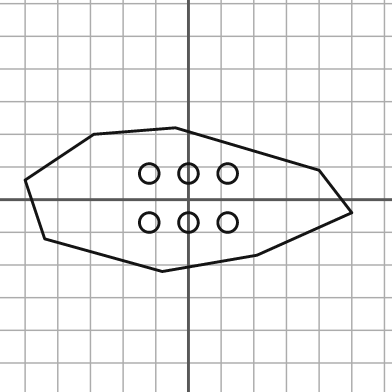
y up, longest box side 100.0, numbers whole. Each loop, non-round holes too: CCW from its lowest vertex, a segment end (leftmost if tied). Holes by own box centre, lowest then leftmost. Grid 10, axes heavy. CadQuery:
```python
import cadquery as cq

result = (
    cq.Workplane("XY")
    .moveTo(-8.0, -22.0)
    .lineTo(21.0, -17.0)
    .lineTo(50.0, -4.0)
    .lineTo(40.0, 9.0)
    .lineTo(-4.0, 22.0)
    .lineTo(-29.0, 20.0)
    .lineTo(-50.0, 6.0)
    .lineTo(-44.0, -12.0)
    .close()
    .moveTo(-12.0, -7.0)
    .circle(3.0)
    .moveTo(0.0, -7.0)
    .circle(3.0)
    .moveTo(12.0, -7.0)
    .circle(3.0)
    .moveTo(-12.0, 8.0)
    .circle(3.0)
    .moveTo(0.0, 8.0)
    .circle(3.0)
    .moveTo(12.0, 8.0)
    .circle(3.0)
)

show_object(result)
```